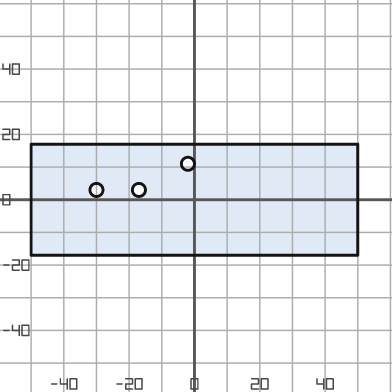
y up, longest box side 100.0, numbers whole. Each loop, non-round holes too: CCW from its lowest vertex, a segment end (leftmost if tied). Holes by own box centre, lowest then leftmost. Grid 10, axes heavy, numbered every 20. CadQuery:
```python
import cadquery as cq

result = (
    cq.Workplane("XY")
    .moveTo(-50.0, -17.0)
    .lineTo(50.0, -17.0)
    .lineTo(50.0, 17.0)
    .lineTo(-50.0, 17.0)
    .close()
    .moveTo(-30.0, 3.0)
    .circle(2.0)
    .moveTo(-17.0, 3.0)
    .circle(2.0)
    .moveTo(-2.0, 11.0)
    .circle(2.0)
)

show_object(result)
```